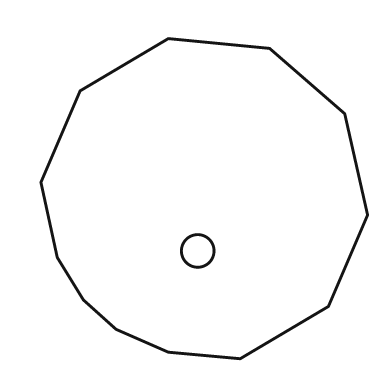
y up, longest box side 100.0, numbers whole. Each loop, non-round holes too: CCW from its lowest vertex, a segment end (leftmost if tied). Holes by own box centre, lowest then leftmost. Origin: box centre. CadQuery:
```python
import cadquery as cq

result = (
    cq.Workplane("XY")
    .moveTo(11.0, -49.0)
    .lineTo(38.0, -33.0)
    .lineTo(50.0, -5.0)
    .lineTo(43.0, 26.0)
    .lineTo(20.0, 46.0)
    .lineTo(-11.0, 49.0)
    .lineTo(-38.0, 33.0)
    .lineTo(-50.0, 5.0)
    .lineTo(-45.0, -18.0)
    .lineTo(-37.0, -31.0)
    .lineTo(-27.0, -40.0)
    .lineTo(-11.0, -47.0)
    .close()
    .moveTo(-2.0, -16.0)
    .circle(5.0)
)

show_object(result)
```